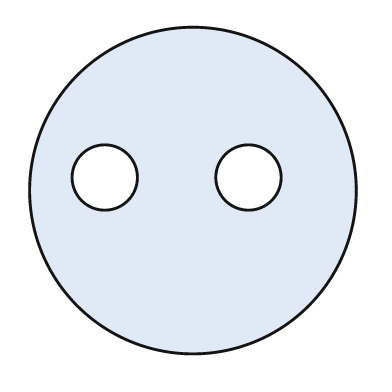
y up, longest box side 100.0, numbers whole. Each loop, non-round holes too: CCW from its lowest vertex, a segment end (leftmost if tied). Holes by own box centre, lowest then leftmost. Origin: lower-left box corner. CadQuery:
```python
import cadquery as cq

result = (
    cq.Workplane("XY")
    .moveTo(50.0, 50.0)
    .circle(50.0)
    .moveTo(23.0, 54.0)
    .circle(10.0)
    .moveTo(67.0, 54.0)
    .circle(10.0)
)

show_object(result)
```